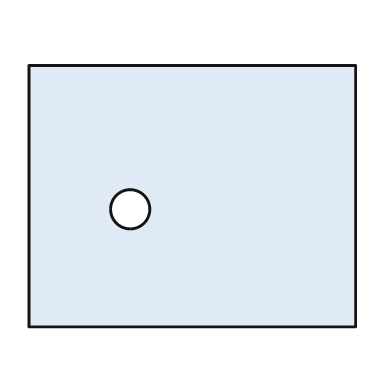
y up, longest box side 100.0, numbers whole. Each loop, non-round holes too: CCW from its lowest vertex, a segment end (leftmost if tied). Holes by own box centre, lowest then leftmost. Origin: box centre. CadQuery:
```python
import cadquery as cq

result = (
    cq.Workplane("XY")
    .moveTo(-50.0, -40.0)
    .lineTo(50.0, -40.0)
    .lineTo(50.0, 40.0)
    .lineTo(-50.0, 40.0)
    .close()
    .moveTo(-19.0, -4.0)
    .circle(6.0)
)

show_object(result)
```